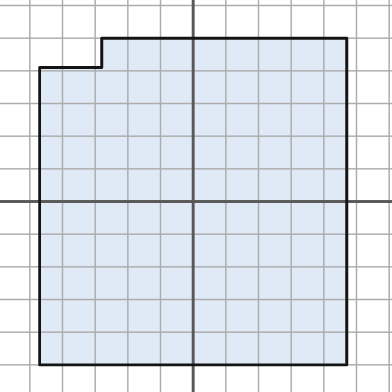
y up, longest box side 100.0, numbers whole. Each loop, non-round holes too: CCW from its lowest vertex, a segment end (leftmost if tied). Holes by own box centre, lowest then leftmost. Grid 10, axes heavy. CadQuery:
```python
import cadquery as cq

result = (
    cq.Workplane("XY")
    .moveTo(-47.0, -50.0)
    .lineTo(47.0, -50.0)
    .lineTo(47.0, 50.0)
    .lineTo(-28.0, 50.0)
    .lineTo(-28.0, 41.0)
    .lineTo(-47.0, 41.0)
    .close()
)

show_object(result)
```